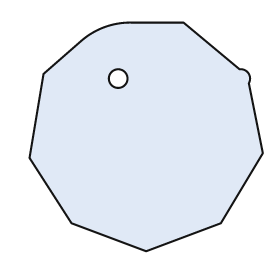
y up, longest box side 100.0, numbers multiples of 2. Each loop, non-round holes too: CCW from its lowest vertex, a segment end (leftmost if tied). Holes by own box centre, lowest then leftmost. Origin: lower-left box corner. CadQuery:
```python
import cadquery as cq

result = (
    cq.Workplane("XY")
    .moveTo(50.0, 0.0)
    .lineTo(82.0, 12.0)
    .lineTo(100.0, 42.0)
    .lineTo(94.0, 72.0)
    .threePointArc((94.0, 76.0), (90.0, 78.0))
    .lineTo(66.0, 98.0)
    .lineTo(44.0, 98.0)
    .threePointArc((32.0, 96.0), (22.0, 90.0))
    .lineTo(6.0, 76.0)
    .lineTo(0.0, 40.0)
    .lineTo(18.0, 12.0)
    .close()
    .moveTo(38.0, 74.0)
    .circle(4.0)
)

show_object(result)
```